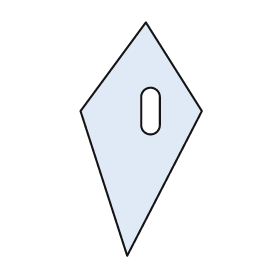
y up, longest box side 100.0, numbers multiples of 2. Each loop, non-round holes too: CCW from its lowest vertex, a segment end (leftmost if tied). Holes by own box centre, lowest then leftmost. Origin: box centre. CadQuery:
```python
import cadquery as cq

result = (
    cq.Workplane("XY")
    .moveTo(-6.0, -50.0)
    .lineTo(26.0, 12.0)
    .lineTo(2.0, 50.0)
    .lineTo(-26.0, 12.0)
    .close()
    .moveTo(0.0, 6.0)
    .threePointArc((4.0, 2.0), (8.0, 6.0))
    .lineTo(8.0, 18.0)
    .threePointArc((4.0, 22.0), (0.0, 18.0))
    .close()
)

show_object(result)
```